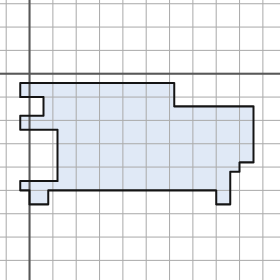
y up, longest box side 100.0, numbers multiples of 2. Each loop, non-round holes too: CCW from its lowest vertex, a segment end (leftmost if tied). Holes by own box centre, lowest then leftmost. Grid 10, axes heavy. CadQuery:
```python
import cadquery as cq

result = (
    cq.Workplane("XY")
    .moveTo(0.0, -56.0)
    .lineTo(8.0, -56.0)
    .lineTo(8.0, -50.0)
    .lineTo(80.0, -50.0)
    .lineTo(80.0, -56.0)
    .lineTo(86.0, -56.0)
    .lineTo(86.0, -42.0)
    .lineTo(90.0, -42.0)
    .lineTo(90.0, -38.0)
    .lineTo(96.0, -38.0)
    .lineTo(96.0, -14.0)
    .lineTo(62.0, -14.0)
    .lineTo(62.0, -4.0)
    .lineTo(-4.0, -4.0)
    .lineTo(-4.0, -10.0)
    .lineTo(6.0, -10.0)
    .lineTo(6.0, -18.0)
    .lineTo(-4.0, -18.0)
    .lineTo(-4.0, -24.0)
    .lineTo(12.0, -24.0)
    .lineTo(12.0, -46.0)
    .lineTo(-4.0, -46.0)
    .lineTo(-4.0, -50.0)
    .lineTo(0.0, -50.0)
    .close()
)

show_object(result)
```